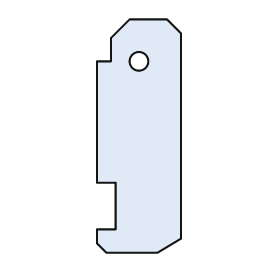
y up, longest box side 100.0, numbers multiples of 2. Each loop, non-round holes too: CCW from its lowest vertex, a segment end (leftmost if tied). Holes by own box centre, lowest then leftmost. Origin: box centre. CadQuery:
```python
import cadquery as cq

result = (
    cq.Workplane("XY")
    .moveTo(-14.0, -50.0)
    .lineTo(8.0, -50.0)
    .lineTo(18.0, -44.0)
    .lineTo(18.0, 44.0)
    .lineTo(12.0, 50.0)
    .lineTo(-4.0, 50.0)
    .lineTo(-12.0, 42.0)
    .lineTo(-12.0, 32.0)
    .lineTo(-18.0, 32.0)
    .lineTo(-18.0, -20.0)
    .lineTo(-10.0, -20.0)
    .lineTo(-10.0, -40.0)
    .lineTo(-18.0, -40.0)
    .lineTo(-18.0, -46.0)
    .close()
    .moveTo(0.0, 32.0)
    .circle(4.0)
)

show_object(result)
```